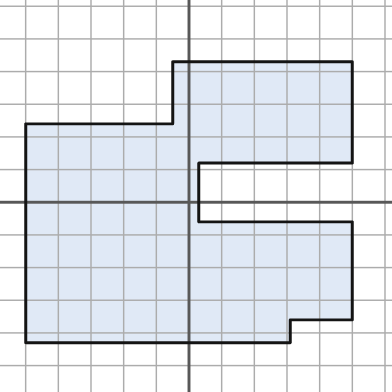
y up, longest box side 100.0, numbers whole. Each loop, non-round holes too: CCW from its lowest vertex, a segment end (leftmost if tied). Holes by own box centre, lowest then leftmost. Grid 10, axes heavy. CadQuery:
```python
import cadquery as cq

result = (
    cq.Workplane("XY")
    .moveTo(-50.0, -43.0)
    .lineTo(31.0, -43.0)
    .lineTo(31.0, -36.0)
    .lineTo(50.0, -36.0)
    .lineTo(50.0, -6.0)
    .lineTo(3.0, -6.0)
    .lineTo(3.0, 12.0)
    .lineTo(50.0, 12.0)
    .lineTo(50.0, 43.0)
    .lineTo(-5.0, 43.0)
    .lineTo(-5.0, 24.0)
    .lineTo(-50.0, 24.0)
    .close()
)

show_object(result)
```